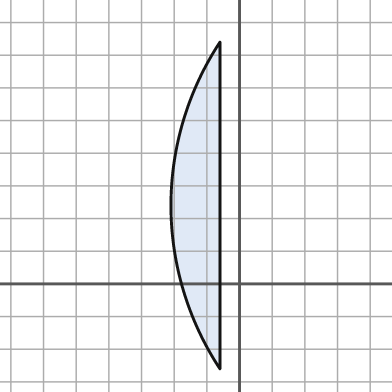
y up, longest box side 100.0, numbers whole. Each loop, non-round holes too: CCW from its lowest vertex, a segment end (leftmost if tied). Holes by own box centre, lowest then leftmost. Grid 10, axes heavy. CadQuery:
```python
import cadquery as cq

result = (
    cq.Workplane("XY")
    .moveTo(-6.0, -26.0)
    .lineTo(-6.0, 74.0)
    .threePointArc((-21.0, 24.0), (-6.0, -26.0))
    .close()
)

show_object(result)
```